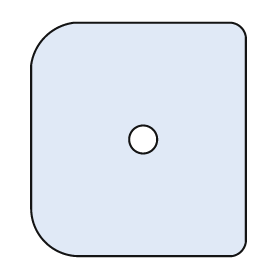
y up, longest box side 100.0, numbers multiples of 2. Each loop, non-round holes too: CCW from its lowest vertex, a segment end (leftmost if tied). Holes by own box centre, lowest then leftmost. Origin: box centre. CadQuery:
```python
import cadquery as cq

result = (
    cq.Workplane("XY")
    .moveTo(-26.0, -50.0)
    .lineTo(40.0, -50.0)
    .threePointArc((44.0, -48.0), (46.0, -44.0))
    .lineTo(46.0, 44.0)
    .threePointArc((44.0, 48.0), (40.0, 50.0))
    .lineTo(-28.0, 50.0)
    .threePointArc((-40.0, 44.0), (-46.0, 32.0))
    .lineTo(-46.0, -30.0)
    .threePointArc((-40.0, -44.0), (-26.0, -50.0))
    .close()
    .moveTo(2.0, 0.0)
    .circle(6.0)
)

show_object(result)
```